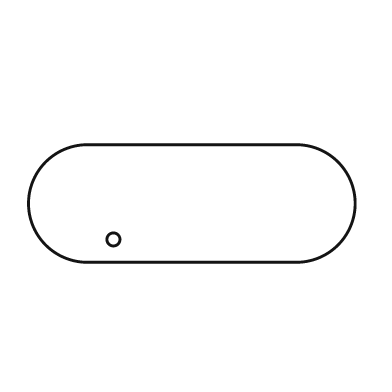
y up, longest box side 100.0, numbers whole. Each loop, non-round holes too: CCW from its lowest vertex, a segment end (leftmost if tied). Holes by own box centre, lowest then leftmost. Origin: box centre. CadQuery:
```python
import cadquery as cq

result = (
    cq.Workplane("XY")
    .moveTo(-32.0, -18.0)
    .lineTo(32.0, -18.0)
    .threePointArc((50.0, 0.0), (32.0, 18.0))
    .lineTo(-32.0, 18.0)
    .threePointArc((-50.0, 0.0), (-32.0, -18.0))
    .close()
    .moveTo(-24.0, -11.0)
    .circle(2.0)
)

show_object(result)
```